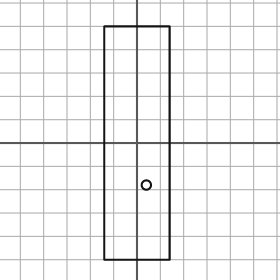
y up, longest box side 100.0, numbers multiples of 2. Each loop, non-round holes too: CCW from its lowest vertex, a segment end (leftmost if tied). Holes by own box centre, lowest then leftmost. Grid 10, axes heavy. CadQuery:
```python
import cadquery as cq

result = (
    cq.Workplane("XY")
    .moveTo(-14.0, -50.0)
    .lineTo(14.0, -50.0)
    .lineTo(14.0, 50.0)
    .lineTo(-14.0, 50.0)
    .close()
    .moveTo(4.0, -18.0)
    .circle(2.0)
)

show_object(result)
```